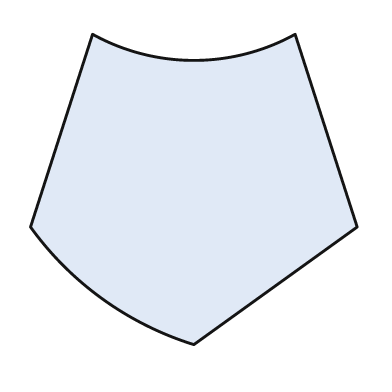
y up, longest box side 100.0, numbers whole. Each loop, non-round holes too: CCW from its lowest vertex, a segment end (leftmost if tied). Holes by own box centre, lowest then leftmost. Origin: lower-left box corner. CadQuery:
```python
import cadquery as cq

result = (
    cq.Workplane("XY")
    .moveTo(50.0, 0.0)
    .lineTo(100.0, 36.0)
    .lineTo(81.0, 95.0)
    .threePointArc((50.0, 87.0), (19.0, 95.0))
    .lineTo(0.0, 36.0)
    .threePointArc((22.0, 14.0), (50.0, 0.0))
    .close()
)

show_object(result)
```